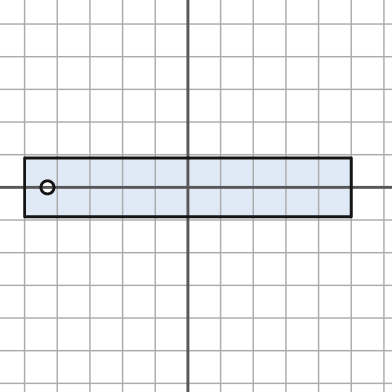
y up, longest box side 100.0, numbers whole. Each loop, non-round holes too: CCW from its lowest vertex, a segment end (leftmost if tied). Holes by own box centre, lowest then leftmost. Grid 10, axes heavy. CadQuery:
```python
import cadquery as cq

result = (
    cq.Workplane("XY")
    .moveTo(-50.0, -9.0)
    .lineTo(50.0, -9.0)
    .lineTo(50.0, 9.0)
    .lineTo(-50.0, 9.0)
    .close()
    .moveTo(-43.0, 0.0)
    .circle(2.0)
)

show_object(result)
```